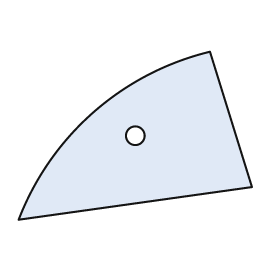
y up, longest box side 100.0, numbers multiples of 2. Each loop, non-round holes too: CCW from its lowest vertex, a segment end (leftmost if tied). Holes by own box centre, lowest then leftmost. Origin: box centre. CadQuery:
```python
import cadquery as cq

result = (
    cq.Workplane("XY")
    .moveTo(-50.0, -36.0)
    .lineTo(50.0, -22.0)
    .lineTo(32.0, 36.0)
    .threePointArc((-18.0, 10.0), (-50.0, -36.0))
    .close()
    .moveTo(0.0, 0.0)
    .circle(4.0)
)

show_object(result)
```